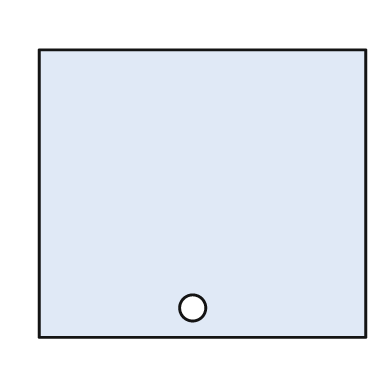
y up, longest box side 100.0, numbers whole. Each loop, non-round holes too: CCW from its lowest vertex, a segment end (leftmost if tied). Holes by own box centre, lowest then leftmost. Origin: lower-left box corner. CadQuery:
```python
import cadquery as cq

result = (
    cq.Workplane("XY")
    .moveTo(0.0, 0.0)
    .lineTo(100.0, 0.0)
    .lineTo(100.0, 88.0)
    .lineTo(0.0, 88.0)
    .close()
    .moveTo(47.0, 9.0)
    .circle(4.0)
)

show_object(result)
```